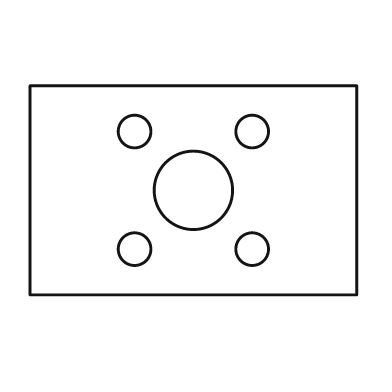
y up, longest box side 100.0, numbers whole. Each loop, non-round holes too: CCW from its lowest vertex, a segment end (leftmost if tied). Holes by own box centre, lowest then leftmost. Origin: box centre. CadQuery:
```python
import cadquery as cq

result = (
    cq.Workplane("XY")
    .moveTo(-50.0, -32.0)
    .lineTo(50.0, -32.0)
    .lineTo(50.0, 32.0)
    .lineTo(-50.0, 32.0)
    .close()
    .moveTo(-18.0, -18.0)
    .circle(5.0)
    .moveTo(18.0, -18.0)
    .circle(5.0)
    .moveTo(0.0, 0.0)
    .circle(12.0)
    .moveTo(-18.0, 18.0)
    .circle(5.0)
    .moveTo(18.0, 18.0)
    .circle(5.0)
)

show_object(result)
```